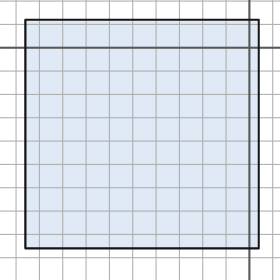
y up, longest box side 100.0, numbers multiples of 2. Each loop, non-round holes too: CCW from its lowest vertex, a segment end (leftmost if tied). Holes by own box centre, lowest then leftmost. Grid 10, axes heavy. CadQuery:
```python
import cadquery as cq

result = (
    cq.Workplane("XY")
    .moveTo(-96.0, -86.0)
    .lineTo(4.0, -86.0)
    .lineTo(4.0, 12.0)
    .lineTo(-96.0, 12.0)
    .close()
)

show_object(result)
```